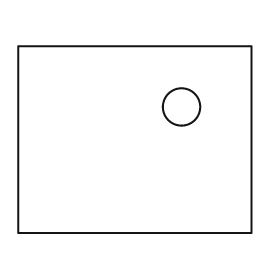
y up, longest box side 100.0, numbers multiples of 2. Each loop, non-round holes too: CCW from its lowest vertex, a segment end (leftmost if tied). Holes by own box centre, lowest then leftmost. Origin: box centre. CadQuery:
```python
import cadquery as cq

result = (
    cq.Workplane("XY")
    .moveTo(-50.0, -40.0)
    .lineTo(50.0, -40.0)
    .lineTo(50.0, 40.0)
    .lineTo(-50.0, 40.0)
    .close()
    .moveTo(20.0, 14.0)
    .circle(8.0)
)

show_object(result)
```